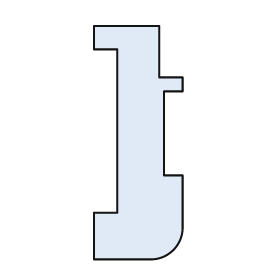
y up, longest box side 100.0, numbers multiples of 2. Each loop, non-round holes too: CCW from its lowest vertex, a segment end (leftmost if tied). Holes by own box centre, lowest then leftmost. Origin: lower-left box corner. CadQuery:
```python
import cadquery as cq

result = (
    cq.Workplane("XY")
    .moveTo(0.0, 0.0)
    .lineTo(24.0, 0.0)
    .threePointArc((34.0, 4.0), (38.0, 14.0))
    .lineTo(38.0, 36.0)
    .lineTo(30.0, 36.0)
    .lineTo(30.0, 72.0)
    .lineTo(38.0, 72.0)
    .lineTo(38.0, 78.0)
    .lineTo(28.0, 78.0)
    .lineTo(28.0, 100.0)
    .lineTo(0.0, 100.0)
    .lineTo(0.0, 90.0)
    .lineTo(10.0, 90.0)
    .lineTo(10.0, 20.0)
    .lineTo(0.0, 20.0)
    .close()
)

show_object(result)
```